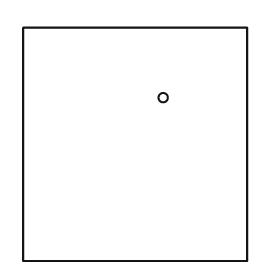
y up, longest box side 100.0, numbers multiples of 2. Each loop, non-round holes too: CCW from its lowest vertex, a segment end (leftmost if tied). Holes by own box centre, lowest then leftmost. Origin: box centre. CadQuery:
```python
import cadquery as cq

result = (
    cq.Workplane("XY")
    .moveTo(-48.0, -50.0)
    .lineTo(48.0, -50.0)
    .lineTo(48.0, 50.0)
    .lineTo(-48.0, 50.0)
    .close()
    .moveTo(12.0, 20.0)
    .circle(2.0)
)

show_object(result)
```